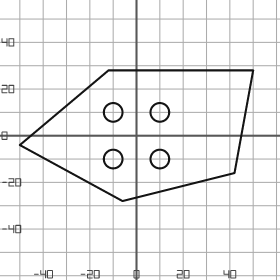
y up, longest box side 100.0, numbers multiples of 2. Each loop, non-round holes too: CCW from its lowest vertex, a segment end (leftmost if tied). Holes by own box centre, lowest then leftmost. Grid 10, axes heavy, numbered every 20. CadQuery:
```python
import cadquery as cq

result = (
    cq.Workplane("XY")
    .moveTo(-6.0, -28.0)
    .lineTo(42.0, -16.0)
    .lineTo(50.0, 28.0)
    .lineTo(-12.0, 28.0)
    .lineTo(-50.0, -4.0)
    .close()
    .moveTo(-10.0, -10.0)
    .circle(4.0)
    .moveTo(10.0, -10.0)
    .circle(4.0)
    .moveTo(-10.0, 10.0)
    .circle(4.0)
    .moveTo(10.0, 10.0)
    .circle(4.0)
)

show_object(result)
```